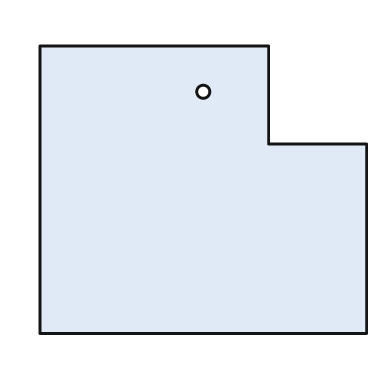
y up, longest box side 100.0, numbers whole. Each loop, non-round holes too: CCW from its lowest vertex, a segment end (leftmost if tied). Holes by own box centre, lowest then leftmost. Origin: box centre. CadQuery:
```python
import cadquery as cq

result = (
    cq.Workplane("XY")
    .moveTo(-50.0, -44.0)
    .lineTo(50.0, -44.0)
    .lineTo(50.0, 14.0)
    .lineTo(20.0, 14.0)
    .lineTo(20.0, 44.0)
    .lineTo(-50.0, 44.0)
    .close()
    .moveTo(0.0, 30.0)
    .circle(2.0)
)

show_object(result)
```